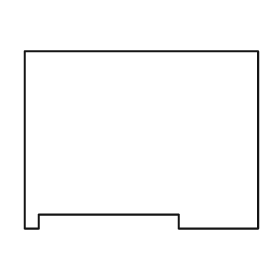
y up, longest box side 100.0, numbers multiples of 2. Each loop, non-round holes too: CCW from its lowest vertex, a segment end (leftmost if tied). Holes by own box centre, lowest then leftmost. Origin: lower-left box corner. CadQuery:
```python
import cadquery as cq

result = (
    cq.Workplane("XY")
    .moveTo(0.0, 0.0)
    .lineTo(6.0, 0.0)
    .lineTo(6.0, 6.0)
    .lineTo(66.0, 6.0)
    .lineTo(66.0, 0.0)
    .lineTo(100.0, 0.0)
    .lineTo(100.0, 76.0)
    .lineTo(0.0, 76.0)
    .close()
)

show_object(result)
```